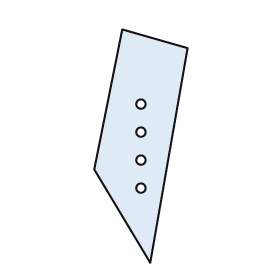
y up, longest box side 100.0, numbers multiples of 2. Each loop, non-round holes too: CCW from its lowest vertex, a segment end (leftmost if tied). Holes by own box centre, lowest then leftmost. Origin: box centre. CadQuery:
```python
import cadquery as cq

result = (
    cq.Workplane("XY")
    .moveTo(4.0, -50.0)
    .lineTo(20.0, 42.0)
    .lineTo(-8.0, 50.0)
    .lineTo(-20.0, -10.0)
    .close()
    .moveTo(0.0, -18.0)
    .circle(2.0)
    .moveTo(0.0, -6.0)
    .circle(2.0)
    .moveTo(0.0, 6.0)
    .circle(2.0)
    .moveTo(0.0, 18.0)
    .circle(2.0)
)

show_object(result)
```